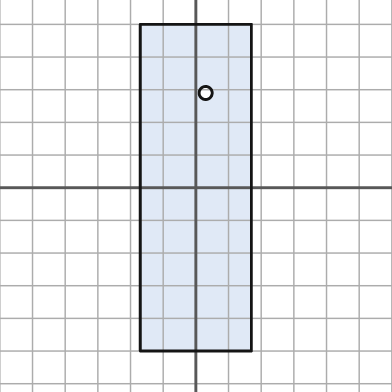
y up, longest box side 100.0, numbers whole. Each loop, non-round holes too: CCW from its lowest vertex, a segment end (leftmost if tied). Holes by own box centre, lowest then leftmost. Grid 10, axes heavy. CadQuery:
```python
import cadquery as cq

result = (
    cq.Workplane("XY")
    .moveTo(-17.0, -50.0)
    .lineTo(17.0, -50.0)
    .lineTo(17.0, 50.0)
    .lineTo(-17.0, 50.0)
    .close()
    .moveTo(3.0, 29.0)
    .circle(2.0)
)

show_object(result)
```